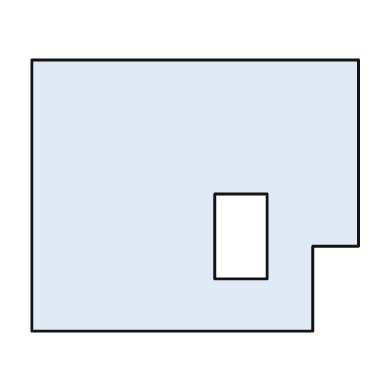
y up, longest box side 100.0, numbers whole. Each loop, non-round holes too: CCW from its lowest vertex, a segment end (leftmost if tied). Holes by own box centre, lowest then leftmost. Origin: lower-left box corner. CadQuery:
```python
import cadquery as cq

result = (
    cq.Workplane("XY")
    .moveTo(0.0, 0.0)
    .lineTo(86.0, 0.0)
    .lineTo(86.0, 26.0)
    .lineTo(100.0, 26.0)
    .lineTo(100.0, 83.0)
    .lineTo(0.0, 83.0)
    .close()
    .moveTo(56.0, 16.0)
    .lineTo(72.0, 16.0)
    .lineTo(72.0, 42.0)
    .lineTo(56.0, 42.0)
    .close()
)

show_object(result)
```